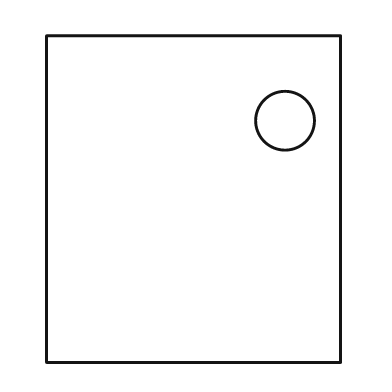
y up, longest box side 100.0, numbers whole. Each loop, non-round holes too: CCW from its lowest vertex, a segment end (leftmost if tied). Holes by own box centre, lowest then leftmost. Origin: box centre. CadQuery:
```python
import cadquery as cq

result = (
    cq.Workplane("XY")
    .moveTo(-45.0, -50.0)
    .lineTo(45.0, -50.0)
    .lineTo(45.0, 50.0)
    .lineTo(-45.0, 50.0)
    .close()
    .moveTo(28.0, 24.0)
    .circle(9.0)
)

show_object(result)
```